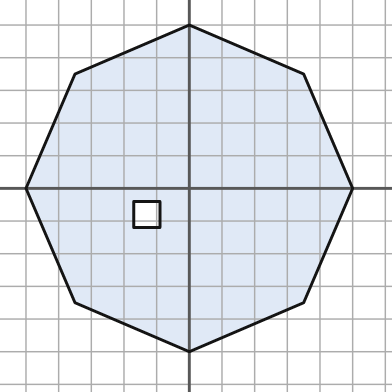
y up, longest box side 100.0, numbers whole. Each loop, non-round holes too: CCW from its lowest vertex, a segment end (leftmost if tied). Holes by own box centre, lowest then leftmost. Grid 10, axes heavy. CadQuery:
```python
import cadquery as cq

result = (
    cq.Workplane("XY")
    .moveTo(0.0, -50.0)
    .lineTo(35.0, -35.0)
    .lineTo(50.0, 0.0)
    .lineTo(35.0, 35.0)
    .lineTo(0.0, 50.0)
    .lineTo(-35.0, 35.0)
    .lineTo(-50.0, 0.0)
    .lineTo(-35.0, -35.0)
    .close()
    .moveTo(-17.0, -12.0)
    .lineTo(-9.0, -12.0)
    .lineTo(-9.0, -4.0)
    .lineTo(-17.0, -4.0)
    .close()
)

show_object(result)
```